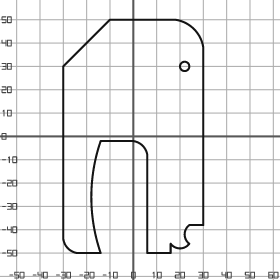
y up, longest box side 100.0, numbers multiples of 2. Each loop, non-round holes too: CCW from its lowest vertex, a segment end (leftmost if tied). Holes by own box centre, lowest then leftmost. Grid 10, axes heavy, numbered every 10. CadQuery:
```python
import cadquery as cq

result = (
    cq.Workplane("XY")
    .moveTo(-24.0, -50.0)
    .lineTo(-14.0, -50.0)
    .threePointArc((-18.0, -26.0), (-14.0, -2.0))
    .lineTo(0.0, -2.0)
    .threePointArc((4.0, -4.0), (6.0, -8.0))
    .lineTo(6.0, -50.0)
    .lineTo(16.0, -50.0)
    .lineTo(16.0, -46.0)
    .threePointArc((20.0, -48.0), (24.0, -46.0))
    .threePointArc((22.0, -42.0), (24.0, -38.0))
    .lineTo(30.0, -38.0)
    .lineTo(30.0, 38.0)
    .threePointArc((26.0, 46.0), (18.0, 50.0))
    .lineTo(-10.0, 50.0)
    .lineTo(-30.0, 30.0)
    .lineTo(-30.0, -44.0)
    .threePointArc((-28.0, -48.0), (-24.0, -50.0))
    .close()
    .moveTo(22.0, 30.0)
    .circle(2.0)
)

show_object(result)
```